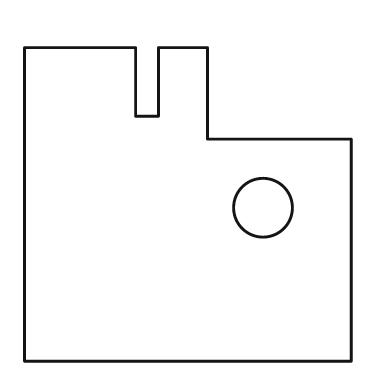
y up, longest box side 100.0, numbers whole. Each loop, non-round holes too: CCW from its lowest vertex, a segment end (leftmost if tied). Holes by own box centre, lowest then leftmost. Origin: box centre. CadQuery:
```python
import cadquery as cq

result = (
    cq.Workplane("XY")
    .moveTo(-50.0, -48.0)
    .lineTo(50.0, -48.0)
    .lineTo(50.0, 20.0)
    .lineTo(6.0, 20.0)
    .lineTo(6.0, 48.0)
    .lineTo(-9.0, 48.0)
    .lineTo(-9.0, 27.0)
    .lineTo(-16.0, 27.0)
    .lineTo(-16.0, 48.0)
    .lineTo(-50.0, 48.0)
    .close()
    .moveTo(23.0, -1.0)
    .circle(9.0)
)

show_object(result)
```